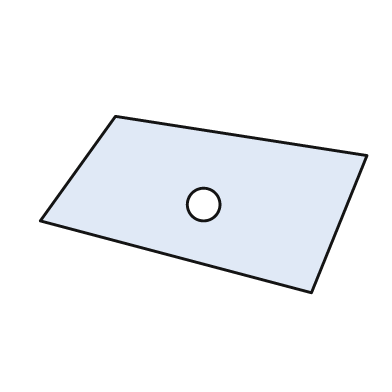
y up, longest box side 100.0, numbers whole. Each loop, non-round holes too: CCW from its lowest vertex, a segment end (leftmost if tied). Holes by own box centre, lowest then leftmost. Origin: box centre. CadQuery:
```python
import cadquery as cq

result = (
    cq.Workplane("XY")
    .moveTo(33.0, -27.0)
    .lineTo(50.0, 15.0)
    .lineTo(-27.0, 27.0)
    .lineTo(-50.0, -5.0)
    .close()
    .moveTo(0.0, 0.0)
    .circle(5.0)
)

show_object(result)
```